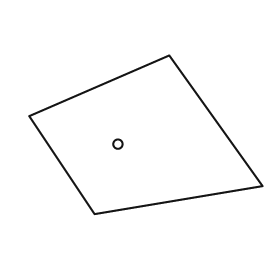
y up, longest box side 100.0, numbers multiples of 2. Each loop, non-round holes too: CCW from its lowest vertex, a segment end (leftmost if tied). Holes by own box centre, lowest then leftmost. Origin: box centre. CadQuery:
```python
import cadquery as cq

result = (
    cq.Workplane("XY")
    .moveTo(-22.0, -34.0)
    .lineTo(50.0, -22.0)
    .lineTo(10.0, 34.0)
    .lineTo(-50.0, 8.0)
    .close()
    .moveTo(-12.0, -4.0)
    .circle(2.0)
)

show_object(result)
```